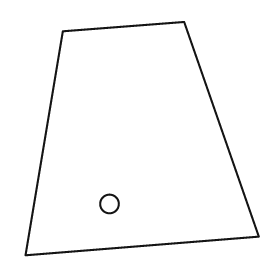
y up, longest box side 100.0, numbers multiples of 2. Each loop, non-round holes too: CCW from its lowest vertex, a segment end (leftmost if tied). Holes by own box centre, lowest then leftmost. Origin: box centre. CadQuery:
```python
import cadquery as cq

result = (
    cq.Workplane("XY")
    .moveTo(-50.0, -50.0)
    .lineTo(50.0, -42.0)
    .lineTo(18.0, 50.0)
    .lineTo(-34.0, 46.0)
    .close()
    .moveTo(-14.0, -28.0)
    .circle(4.0)
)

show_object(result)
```